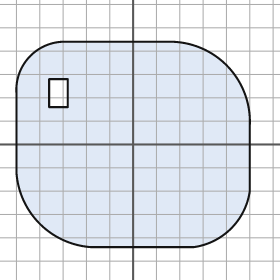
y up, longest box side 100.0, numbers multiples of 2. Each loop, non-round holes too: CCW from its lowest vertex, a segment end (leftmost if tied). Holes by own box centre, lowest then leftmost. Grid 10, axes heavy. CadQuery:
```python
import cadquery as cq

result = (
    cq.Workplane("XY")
    .moveTo(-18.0, -44.0)
    .lineTo(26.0, -44.0)
    .threePointArc((42.0, -36.0), (50.0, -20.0))
    .lineTo(50.0, 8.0)
    .threePointArc((40.0, 34.0), (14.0, 44.0))
    .lineTo(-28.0, 44.0)
    .threePointArc((-44.0, 38.0), (-50.0, 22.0))
    .lineTo(-50.0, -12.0)
    .threePointArc((-40.0, -34.0), (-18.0, -44.0))
    .close()
    .moveTo(-36.0, 16.0)
    .lineTo(-28.0, 16.0)
    .lineTo(-28.0, 28.0)
    .lineTo(-36.0, 28.0)
    .close()
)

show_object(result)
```